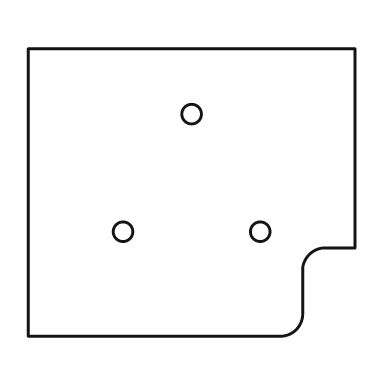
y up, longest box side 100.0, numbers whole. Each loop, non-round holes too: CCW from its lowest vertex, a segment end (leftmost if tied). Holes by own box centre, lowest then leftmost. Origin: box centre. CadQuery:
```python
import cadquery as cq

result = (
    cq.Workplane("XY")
    .moveTo(-50.0, -44.0)
    .lineTo(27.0, -44.0)
    .threePointArc((32.0, -42.0), (34.0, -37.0))
    .lineTo(34.0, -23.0)
    .threePointArc((36.0, -19.0), (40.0, -17.0))
    .lineTo(50.0, -17.0)
    .lineTo(50.0, 44.0)
    .lineTo(-50.0, 44.0)
    .close()
    .moveTo(-21.0, -12.0)
    .circle(3.0)
    .moveTo(21.0, -12.0)
    .circle(3.0)
    .moveTo(0.0, 24.0)
    .circle(3.0)
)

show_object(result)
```